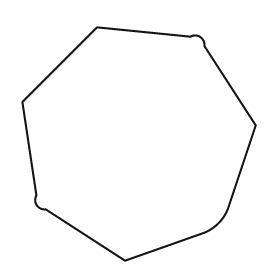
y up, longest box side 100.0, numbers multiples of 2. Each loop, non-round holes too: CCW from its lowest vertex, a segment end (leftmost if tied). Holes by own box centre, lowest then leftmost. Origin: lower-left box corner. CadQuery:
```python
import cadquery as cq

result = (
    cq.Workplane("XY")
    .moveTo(44.0, 0.0)
    .lineTo(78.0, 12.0)
    .threePointArc((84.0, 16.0), (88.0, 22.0))
    .lineTo(100.0, 58.0)
    .lineTo(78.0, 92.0)
    .threePointArc((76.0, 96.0), (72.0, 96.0))
    .lineTo(32.0, 100.0)
    .lineTo(0.0, 68.0)
    .lineTo(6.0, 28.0)
    .threePointArc((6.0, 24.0), (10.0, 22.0))
    .close()
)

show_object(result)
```